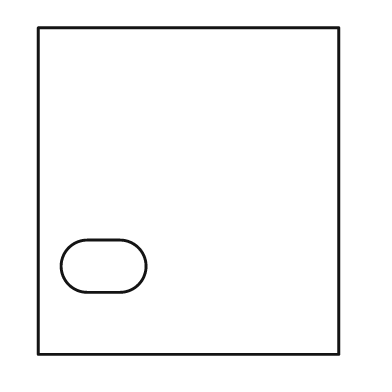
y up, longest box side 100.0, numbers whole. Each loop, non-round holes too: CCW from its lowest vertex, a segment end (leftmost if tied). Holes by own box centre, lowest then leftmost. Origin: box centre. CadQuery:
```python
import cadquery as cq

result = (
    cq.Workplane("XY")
    .moveTo(-46.0, -50.0)
    .lineTo(46.0, -50.0)
    .lineTo(46.0, 50.0)
    .lineTo(-46.0, 50.0)
    .close()
    .moveTo(-31.0, -31.0)
    .lineTo(-21.0, -31.0)
    .threePointArc((-13.0, -23.0), (-21.0, -15.0))
    .lineTo(-31.0, -15.0)
    .threePointArc((-39.0, -23.0), (-31.0, -31.0))
    .close()
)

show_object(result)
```